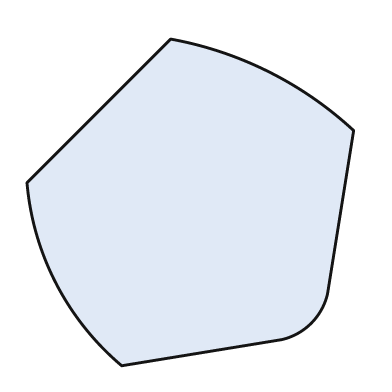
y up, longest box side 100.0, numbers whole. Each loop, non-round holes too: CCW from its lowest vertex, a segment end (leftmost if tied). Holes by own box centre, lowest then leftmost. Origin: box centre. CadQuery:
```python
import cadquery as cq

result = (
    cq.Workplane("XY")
    .moveTo(-21.0, -50.0)
    .lineTo(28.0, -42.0)
    .threePointArc((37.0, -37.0), (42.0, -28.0))
    .lineTo(50.0, 22.0)
    .threePointArc((24.0, 40.0), (-6.0, 50.0))
    .lineTo(-50.0, 6.0)
    .threePointArc((-41.0, -25.0), (-21.0, -50.0))
    .close()
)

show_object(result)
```